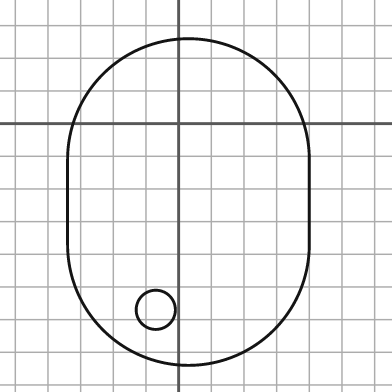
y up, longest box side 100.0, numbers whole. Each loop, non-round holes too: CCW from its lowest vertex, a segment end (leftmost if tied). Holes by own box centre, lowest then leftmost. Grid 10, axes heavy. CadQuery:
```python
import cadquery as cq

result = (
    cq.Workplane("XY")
    .moveTo(-34.0, -37.0)
    .threePointArc((3.0, -74.0), (40.0, -37.0))
    .lineTo(40.0, -11.0)
    .threePointArc((3.0, 26.0), (-34.0, -11.0))
    .close()
    .moveTo(-7.0, -57.0)
    .circle(6.0)
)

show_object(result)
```